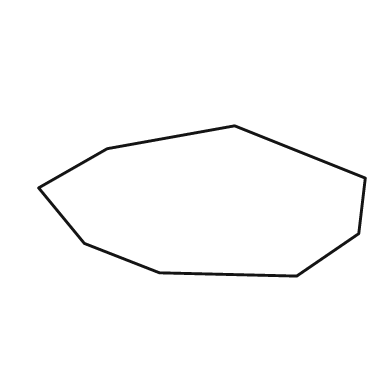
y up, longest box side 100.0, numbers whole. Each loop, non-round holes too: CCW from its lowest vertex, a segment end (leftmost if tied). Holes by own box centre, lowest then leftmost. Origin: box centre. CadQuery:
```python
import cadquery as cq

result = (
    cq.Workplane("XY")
    .moveTo(29.0, -23.0)
    .lineTo(48.0, -10.0)
    .lineTo(50.0, 7.0)
    .lineTo(10.0, 23.0)
    .lineTo(-29.0, 16.0)
    .lineTo(-50.0, 4.0)
    .lineTo(-36.0, -13.0)
    .lineTo(-13.0, -22.0)
    .close()
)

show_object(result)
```